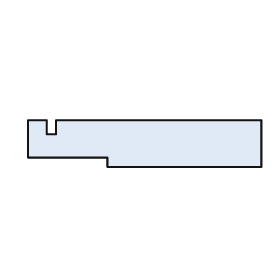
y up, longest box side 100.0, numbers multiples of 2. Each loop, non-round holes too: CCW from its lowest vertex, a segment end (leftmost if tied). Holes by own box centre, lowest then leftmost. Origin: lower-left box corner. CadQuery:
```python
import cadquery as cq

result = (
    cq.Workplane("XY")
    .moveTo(34.0, 0.0)
    .lineTo(100.0, 0.0)
    .lineTo(100.0, 20.0)
    .lineTo(12.0, 20.0)
    .lineTo(12.0, 14.0)
    .lineTo(8.0, 14.0)
    .lineTo(8.0, 20.0)
    .lineTo(0.0, 20.0)
    .lineTo(0.0, 4.0)
    .lineTo(34.0, 4.0)
    .close()
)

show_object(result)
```